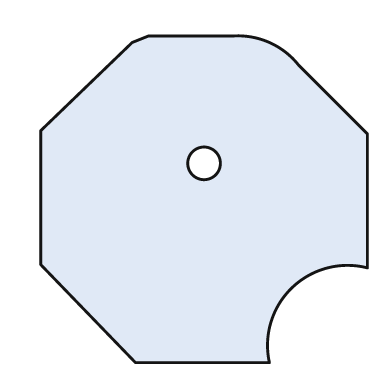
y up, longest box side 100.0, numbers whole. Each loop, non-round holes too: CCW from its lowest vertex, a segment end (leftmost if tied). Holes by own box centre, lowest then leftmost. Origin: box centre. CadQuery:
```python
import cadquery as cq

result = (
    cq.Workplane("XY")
    .moveTo(-21.0, -50.0)
    .lineTo(20.0, -50.0)
    .threePointArc((27.0, -27.0), (50.0, -21.0))
    .lineTo(50.0, 20.0)
    .lineTo(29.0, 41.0)
    .threePointArc((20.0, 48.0), (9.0, 50.0))
    .lineTo(-17.0, 50.0)
    .lineTo(-22.0, 48.0)
    .lineTo(-50.0, 21.0)
    .lineTo(-50.0, -20.0)
    .close()
    .moveTo(0.0, 11.0)
    .circle(5.0)
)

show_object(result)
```